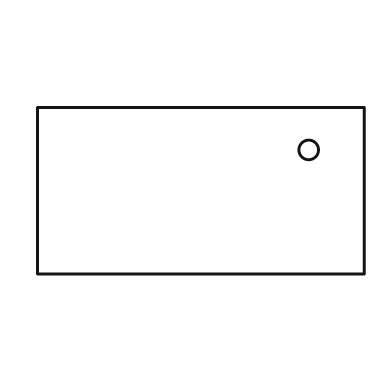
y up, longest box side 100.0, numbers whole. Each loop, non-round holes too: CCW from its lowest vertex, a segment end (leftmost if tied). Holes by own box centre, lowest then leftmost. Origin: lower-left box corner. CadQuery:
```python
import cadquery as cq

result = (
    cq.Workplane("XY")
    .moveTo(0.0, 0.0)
    .lineTo(100.0, 0.0)
    .lineTo(100.0, 51.0)
    .lineTo(0.0, 51.0)
    .close()
    .moveTo(83.0, 38.0)
    .circle(3.0)
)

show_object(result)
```